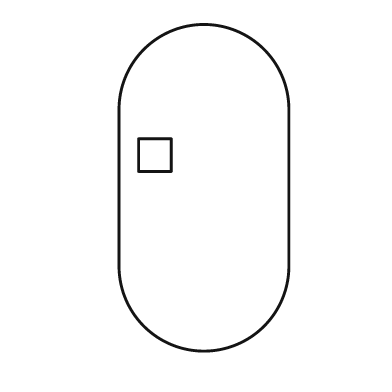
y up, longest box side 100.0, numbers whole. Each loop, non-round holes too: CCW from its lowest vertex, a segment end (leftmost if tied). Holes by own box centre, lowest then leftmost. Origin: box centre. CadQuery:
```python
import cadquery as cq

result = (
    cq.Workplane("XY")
    .moveTo(-26.0, -24.0)
    .threePointArc((0.0, -50.0), (26.0, -24.0))
    .lineTo(26.0, 24.0)
    .threePointArc((0.0, 50.0), (-26.0, 24.0))
    .close()
    .moveTo(-20.0, 5.0)
    .lineTo(-10.0, 5.0)
    .lineTo(-10.0, 15.0)
    .lineTo(-20.0, 15.0)
    .close()
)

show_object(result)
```